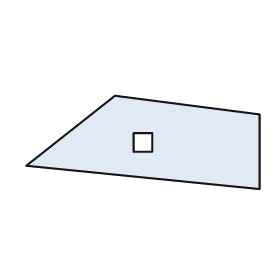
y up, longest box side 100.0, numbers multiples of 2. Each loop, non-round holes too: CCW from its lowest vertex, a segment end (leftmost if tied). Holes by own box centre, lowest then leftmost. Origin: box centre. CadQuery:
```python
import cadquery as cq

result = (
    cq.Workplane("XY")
    .moveTo(50.0, -20.0)
    .lineTo(50.0, 12.0)
    .lineTo(-12.0, 20.0)
    .lineTo(-50.0, -10.0)
    .close()
    .moveTo(-4.0, -4.0)
    .lineTo(4.0, -4.0)
    .lineTo(4.0, 4.0)
    .lineTo(-4.0, 4.0)
    .close()
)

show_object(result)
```